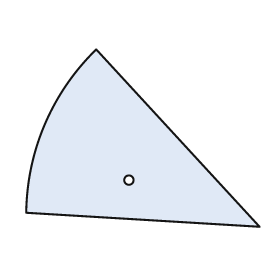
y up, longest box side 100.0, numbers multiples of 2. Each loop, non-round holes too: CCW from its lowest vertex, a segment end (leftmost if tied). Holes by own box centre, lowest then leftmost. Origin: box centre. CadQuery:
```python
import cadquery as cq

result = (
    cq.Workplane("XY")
    .moveTo(50.0, -38.0)
    .lineTo(-20.0, 38.0)
    .threePointArc((-42.0, 6.0), (-50.0, -32.0))
    .close()
    .moveTo(-6.0, -18.0)
    .circle(2.0)
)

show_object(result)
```